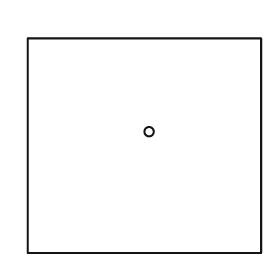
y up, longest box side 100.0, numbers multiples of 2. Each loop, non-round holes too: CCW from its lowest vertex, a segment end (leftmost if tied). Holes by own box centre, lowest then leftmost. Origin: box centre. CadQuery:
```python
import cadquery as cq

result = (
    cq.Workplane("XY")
    .moveTo(-50.0, -46.0)
    .lineTo(50.0, -46.0)
    .lineTo(50.0, 46.0)
    .lineTo(-50.0, 46.0)
    .close()
    .moveTo(2.0, 6.0)
    .circle(2.0)
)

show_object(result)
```